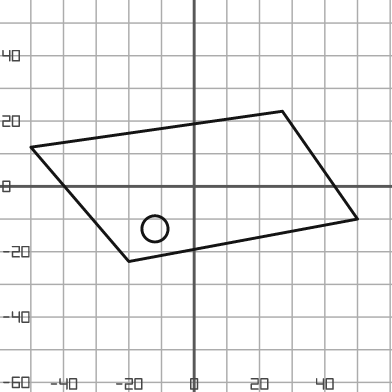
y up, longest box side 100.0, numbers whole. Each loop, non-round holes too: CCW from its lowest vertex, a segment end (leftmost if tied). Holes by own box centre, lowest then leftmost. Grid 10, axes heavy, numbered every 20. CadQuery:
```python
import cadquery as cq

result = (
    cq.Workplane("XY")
    .moveTo(-20.0, -23.0)
    .lineTo(50.0, -10.0)
    .lineTo(27.0, 23.0)
    .lineTo(-50.0, 12.0)
    .close()
    .moveTo(-12.0, -13.0)
    .circle(4.0)
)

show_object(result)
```